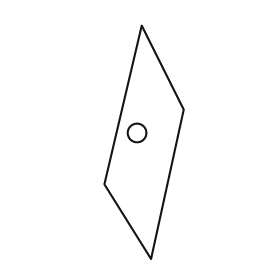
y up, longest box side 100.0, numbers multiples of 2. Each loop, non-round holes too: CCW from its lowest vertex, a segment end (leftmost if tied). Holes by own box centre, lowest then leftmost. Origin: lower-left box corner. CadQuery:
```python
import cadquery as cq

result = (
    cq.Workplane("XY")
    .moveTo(20.0, 0.0)
    .lineTo(34.0, 64.0)
    .lineTo(16.0, 100.0)
    .lineTo(0.0, 32.0)
    .close()
    .moveTo(14.0, 54.0)
    .circle(4.0)
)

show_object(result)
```